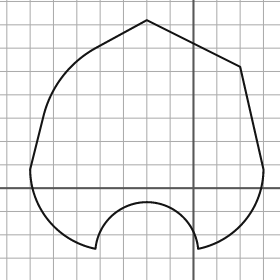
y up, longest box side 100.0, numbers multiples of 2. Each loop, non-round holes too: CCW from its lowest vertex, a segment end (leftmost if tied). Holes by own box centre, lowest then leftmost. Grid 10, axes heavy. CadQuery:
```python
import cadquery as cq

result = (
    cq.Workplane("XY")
    .moveTo(-42.0, -26.0)
    .threePointArc((-20.0, -6.0), (2.0, -26.0))
    .threePointArc((22.0, -14.0), (30.0, 8.0))
    .lineTo(20.0, 52.0)
    .lineTo(-20.0, 72.0)
    .lineTo(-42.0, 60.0)
    .threePointArc((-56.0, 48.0), (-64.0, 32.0))
    .lineTo(-70.0, 8.0)
    .threePointArc((-62.0, -14.0), (-42.0, -26.0))
    .close()
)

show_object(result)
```